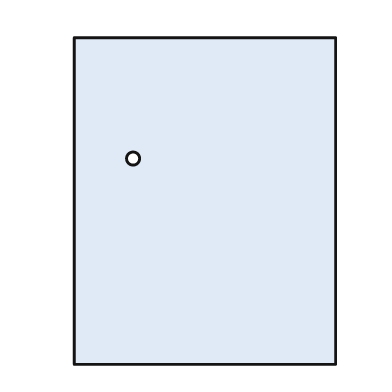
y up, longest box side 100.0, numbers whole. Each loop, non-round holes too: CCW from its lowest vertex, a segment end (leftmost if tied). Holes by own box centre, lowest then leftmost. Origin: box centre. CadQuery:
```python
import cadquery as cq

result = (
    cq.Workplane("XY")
    .moveTo(-40.0, -50.0)
    .lineTo(40.0, -50.0)
    .lineTo(40.0, 50.0)
    .lineTo(-40.0, 50.0)
    .close()
    .moveTo(-22.0, 13.0)
    .circle(2.0)
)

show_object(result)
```